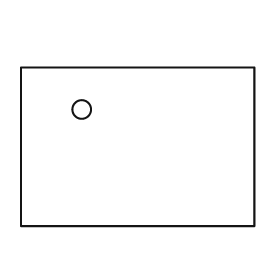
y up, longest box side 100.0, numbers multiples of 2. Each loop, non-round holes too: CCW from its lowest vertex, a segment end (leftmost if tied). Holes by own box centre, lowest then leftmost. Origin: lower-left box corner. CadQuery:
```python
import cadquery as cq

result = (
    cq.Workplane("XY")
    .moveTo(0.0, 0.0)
    .lineTo(100.0, 0.0)
    .lineTo(100.0, 68.0)
    .lineTo(0.0, 68.0)
    .close()
    .moveTo(26.0, 50.0)
    .circle(4.0)
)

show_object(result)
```